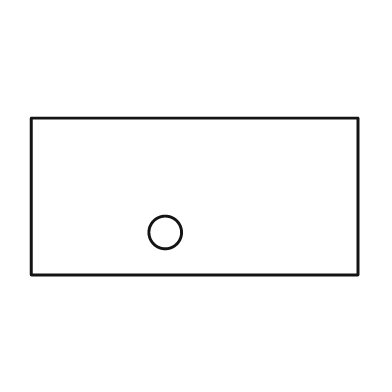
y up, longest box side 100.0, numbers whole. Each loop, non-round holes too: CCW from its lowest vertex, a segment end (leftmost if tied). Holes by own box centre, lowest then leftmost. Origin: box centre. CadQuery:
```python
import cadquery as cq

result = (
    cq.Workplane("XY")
    .moveTo(-50.0, -24.0)
    .lineTo(50.0, -24.0)
    .lineTo(50.0, 24.0)
    .lineTo(-50.0, 24.0)
    .close()
    .moveTo(-9.0, -11.0)
    .circle(5.0)
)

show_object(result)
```